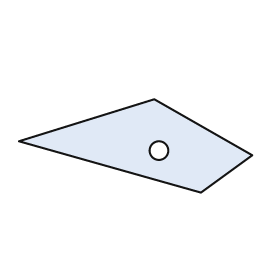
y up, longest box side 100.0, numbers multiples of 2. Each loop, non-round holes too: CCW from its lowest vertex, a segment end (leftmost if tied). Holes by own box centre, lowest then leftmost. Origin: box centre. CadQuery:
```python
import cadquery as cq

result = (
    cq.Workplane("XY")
    .moveTo(28.0, -20.0)
    .lineTo(50.0, -4.0)
    .lineTo(8.0, 20.0)
    .lineTo(-50.0, 2.0)
    .close()
    .moveTo(10.0, -2.0)
    .circle(4.0)
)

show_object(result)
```